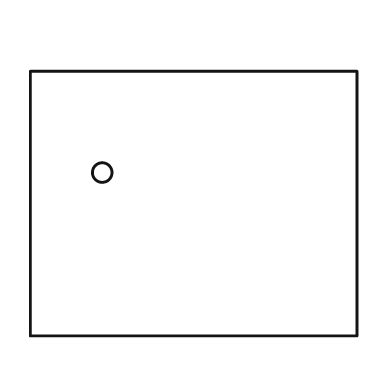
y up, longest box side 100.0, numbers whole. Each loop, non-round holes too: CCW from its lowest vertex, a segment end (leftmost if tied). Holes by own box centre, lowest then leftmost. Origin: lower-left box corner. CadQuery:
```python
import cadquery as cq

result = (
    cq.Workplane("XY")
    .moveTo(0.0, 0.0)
    .lineTo(100.0, 0.0)
    .lineTo(100.0, 81.0)
    .lineTo(0.0, 81.0)
    .close()
    .moveTo(22.0, 50.0)
    .circle(3.0)
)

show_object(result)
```